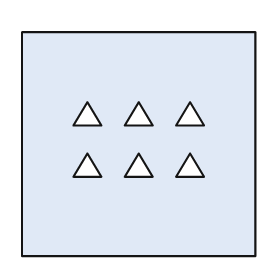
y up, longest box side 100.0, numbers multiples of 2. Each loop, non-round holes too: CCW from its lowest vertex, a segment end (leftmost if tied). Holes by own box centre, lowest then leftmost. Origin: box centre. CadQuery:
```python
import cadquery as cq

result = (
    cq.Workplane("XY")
    .moveTo(-50.0, -48.0)
    .lineTo(50.0, -48.0)
    .lineTo(50.0, 48.0)
    .lineTo(-50.0, 48.0)
    .close()
    .moveTo(-28.0, -14.0)
    .lineTo(-16.0, -14.0)
    .lineTo(-22.0, -4.0)
    .close()
    .moveTo(-6.0, -14.0)
    .lineTo(6.0, -14.0)
    .lineTo(0.0, -4.0)
    .close()
    .moveTo(16.0, -14.0)
    .lineTo(28.0, -14.0)
    .lineTo(22.0, -4.0)
    .close()
    .moveTo(-28.0, 8.0)
    .lineTo(-16.0, 8.0)
    .lineTo(-22.0, 18.0)
    .close()
    .moveTo(-6.0, 8.0)
    .lineTo(6.0, 8.0)
    .lineTo(0.0, 18.0)
    .close()
    .moveTo(16.0, 8.0)
    .lineTo(28.0, 8.0)
    .lineTo(22.0, 18.0)
    .close()
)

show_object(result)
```